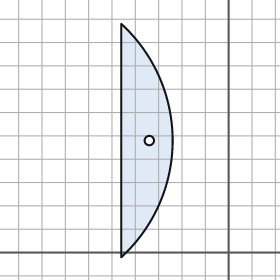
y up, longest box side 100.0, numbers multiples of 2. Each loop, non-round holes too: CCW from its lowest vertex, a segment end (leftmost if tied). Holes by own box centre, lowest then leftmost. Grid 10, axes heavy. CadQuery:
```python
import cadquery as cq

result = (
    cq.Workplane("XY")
    .moveTo(-46.0, -2.0)
    .threePointArc((-24.0, 48.0), (-46.0, 98.0))
    .close()
    .moveTo(-34.0, 48.0)
    .circle(2.0)
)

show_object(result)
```